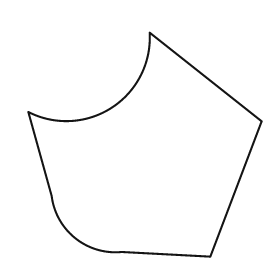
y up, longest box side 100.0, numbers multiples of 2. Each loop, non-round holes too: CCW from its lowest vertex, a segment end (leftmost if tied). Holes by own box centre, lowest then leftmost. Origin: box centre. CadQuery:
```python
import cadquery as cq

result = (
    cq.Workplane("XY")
    .moveTo(28.0, -48.0)
    .lineTo(50.0, 10.0)
    .lineTo(2.0, 48.0)
    .threePointArc((-14.0, 16.0), (-50.0, 14.0))
    .lineTo(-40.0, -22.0)
    .threePointArc((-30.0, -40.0), (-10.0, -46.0))
    .close()
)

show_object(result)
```